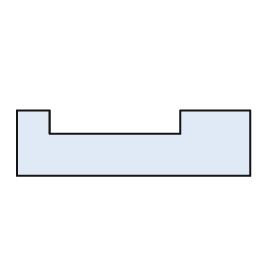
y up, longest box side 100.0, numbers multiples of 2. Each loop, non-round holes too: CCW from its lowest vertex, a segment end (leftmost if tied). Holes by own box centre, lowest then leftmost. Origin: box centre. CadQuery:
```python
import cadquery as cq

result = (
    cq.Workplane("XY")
    .moveTo(-50.0, -14.0)
    .lineTo(50.0, -14.0)
    .lineTo(50.0, 14.0)
    .lineTo(20.0, 14.0)
    .lineTo(20.0, 4.0)
    .lineTo(-36.0, 4.0)
    .lineTo(-36.0, 14.0)
    .lineTo(-50.0, 14.0)
    .close()
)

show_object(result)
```